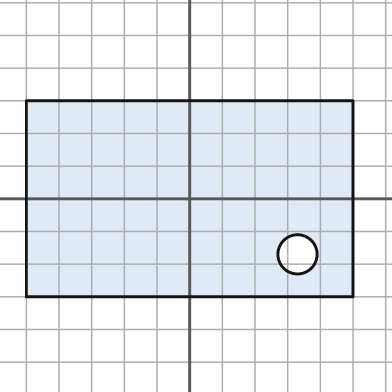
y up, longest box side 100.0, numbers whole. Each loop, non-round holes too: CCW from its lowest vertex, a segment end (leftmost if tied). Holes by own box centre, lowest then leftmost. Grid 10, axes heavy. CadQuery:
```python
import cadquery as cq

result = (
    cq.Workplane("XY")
    .moveTo(-50.0, -30.0)
    .lineTo(50.0, -30.0)
    .lineTo(50.0, 30.0)
    .lineTo(-50.0, 30.0)
    .close()
    .moveTo(33.0, -17.0)
    .circle(6.0)
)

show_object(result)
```